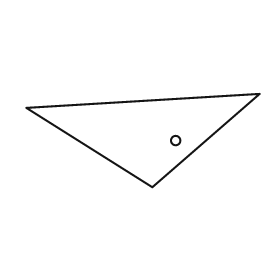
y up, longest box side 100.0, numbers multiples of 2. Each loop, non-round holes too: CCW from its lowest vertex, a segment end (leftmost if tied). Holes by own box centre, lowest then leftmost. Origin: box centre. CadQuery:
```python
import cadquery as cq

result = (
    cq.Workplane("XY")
    .moveTo(4.0, -20.0)
    .lineTo(50.0, 20.0)
    .lineTo(-50.0, 14.0)
    .close()
    .moveTo(14.0, 0.0)
    .circle(2.0)
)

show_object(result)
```